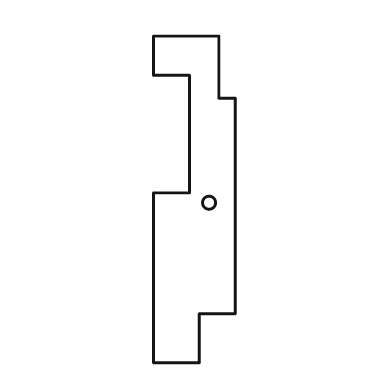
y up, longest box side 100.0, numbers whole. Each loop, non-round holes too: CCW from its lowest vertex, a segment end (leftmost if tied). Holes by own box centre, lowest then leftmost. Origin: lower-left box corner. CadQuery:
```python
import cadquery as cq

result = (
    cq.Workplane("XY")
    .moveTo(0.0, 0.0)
    .lineTo(14.0, 0.0)
    .lineTo(14.0, 15.0)
    .lineTo(25.0, 15.0)
    .lineTo(25.0, 81.0)
    .lineTo(20.0, 81.0)
    .lineTo(20.0, 100.0)
    .lineTo(0.0, 100.0)
    .lineTo(0.0, 88.0)
    .lineTo(11.0, 88.0)
    .lineTo(11.0, 52.0)
    .lineTo(0.0, 52.0)
    .close()
    .moveTo(17.0, 49.0)
    .circle(2.0)
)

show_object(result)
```